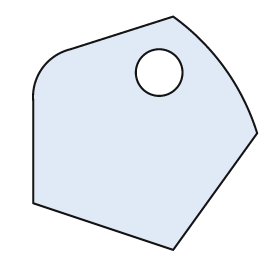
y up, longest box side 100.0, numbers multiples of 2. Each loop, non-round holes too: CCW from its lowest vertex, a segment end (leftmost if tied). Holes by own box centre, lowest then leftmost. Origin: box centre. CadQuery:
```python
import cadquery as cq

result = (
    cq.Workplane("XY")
    .moveTo(12.0, -50.0)
    .lineTo(48.0, 0.0)
    .threePointArc((34.0, 28.0), (12.0, 50.0))
    .lineTo(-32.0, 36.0)
    .threePointArc((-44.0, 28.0), (-48.0, 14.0))
    .lineTo(-48.0, -30.0)
    .close()
    .moveTo(6.0, 26.0)
    .circle(10.0)
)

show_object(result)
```